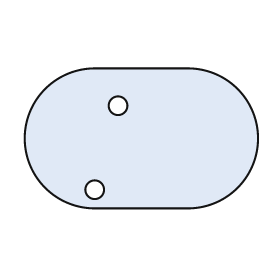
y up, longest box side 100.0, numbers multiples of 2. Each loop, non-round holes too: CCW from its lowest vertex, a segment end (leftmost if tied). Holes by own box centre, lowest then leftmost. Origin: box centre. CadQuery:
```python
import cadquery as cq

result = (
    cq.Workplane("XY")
    .moveTo(-20.0, -30.0)
    .lineTo(20.0, -30.0)
    .threePointArc((50.0, 0.0), (20.0, 30.0))
    .lineTo(-20.0, 30.0)
    .threePointArc((-50.0, 0.0), (-20.0, -30.0))
    .close()
    .moveTo(-20.0, -22.0)
    .circle(4.0)
    .moveTo(-10.0, 14.0)
    .circle(4.0)
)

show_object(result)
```